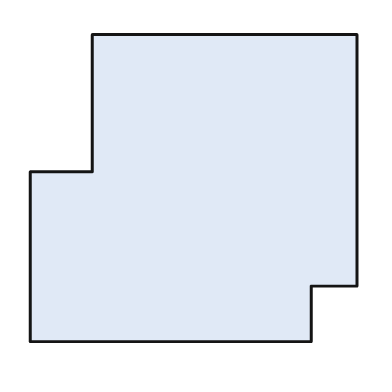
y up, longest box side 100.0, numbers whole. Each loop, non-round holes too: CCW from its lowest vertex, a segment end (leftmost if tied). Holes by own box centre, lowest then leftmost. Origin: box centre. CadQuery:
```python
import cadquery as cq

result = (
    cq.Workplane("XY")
    .moveTo(-50.0, -47.0)
    .lineTo(36.0, -47.0)
    .lineTo(36.0, -30.0)
    .lineTo(50.0, -30.0)
    .lineTo(50.0, 47.0)
    .lineTo(-31.0, 47.0)
    .lineTo(-31.0, 5.0)
    .lineTo(-50.0, 5.0)
    .close()
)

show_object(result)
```